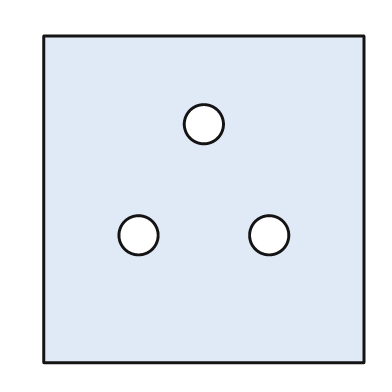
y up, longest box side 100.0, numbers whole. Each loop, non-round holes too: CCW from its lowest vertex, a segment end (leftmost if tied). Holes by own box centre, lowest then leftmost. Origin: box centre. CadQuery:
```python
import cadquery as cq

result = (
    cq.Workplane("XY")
    .moveTo(-49.0, -50.0)
    .lineTo(49.0, -50.0)
    .lineTo(49.0, 50.0)
    .lineTo(-49.0, 50.0)
    .close()
    .moveTo(-20.0, -11.0)
    .circle(6.0)
    .moveTo(20.0, -11.0)
    .circle(6.0)
    .moveTo(0.0, 23.0)
    .circle(6.0)
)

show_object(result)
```